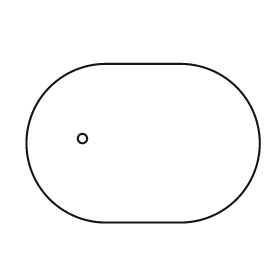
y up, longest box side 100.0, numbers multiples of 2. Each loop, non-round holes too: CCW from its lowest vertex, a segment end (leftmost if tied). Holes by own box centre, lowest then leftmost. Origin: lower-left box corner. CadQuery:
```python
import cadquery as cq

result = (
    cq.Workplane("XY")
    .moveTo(34.0, 0.0)
    .lineTo(66.0, 0.0)
    .threePointArc((100.0, 34.0), (66.0, 68.0))
    .lineTo(34.0, 68.0)
    .threePointArc((0.0, 34.0), (34.0, 0.0))
    .close()
    .moveTo(24.0, 36.0)
    .circle(2.0)
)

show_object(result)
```